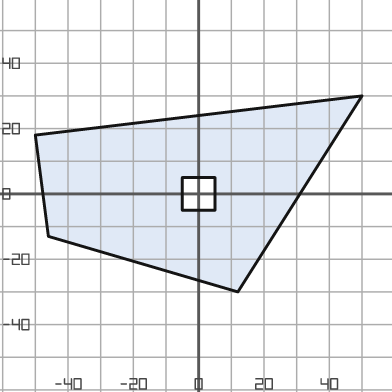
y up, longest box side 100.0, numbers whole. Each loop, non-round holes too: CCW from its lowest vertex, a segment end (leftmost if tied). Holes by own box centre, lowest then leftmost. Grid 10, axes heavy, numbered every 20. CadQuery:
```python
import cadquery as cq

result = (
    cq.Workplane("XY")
    .moveTo(12.0, -30.0)
    .lineTo(50.0, 30.0)
    .lineTo(-50.0, 18.0)
    .lineTo(-46.0, -13.0)
    .close()
    .moveTo(-5.0, -5.0)
    .lineTo(5.0, -5.0)
    .lineTo(5.0, 5.0)
    .lineTo(-5.0, 5.0)
    .close()
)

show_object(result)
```